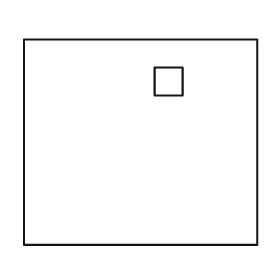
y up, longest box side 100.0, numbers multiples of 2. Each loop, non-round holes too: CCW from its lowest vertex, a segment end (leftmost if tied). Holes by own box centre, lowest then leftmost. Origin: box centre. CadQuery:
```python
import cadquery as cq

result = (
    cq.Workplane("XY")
    .moveTo(-50.0, -44.0)
    .lineTo(50.0, -44.0)
    .lineTo(50.0, 44.0)
    .lineTo(-50.0, 44.0)
    .close()
    .moveTo(6.0, 20.0)
    .lineTo(18.0, 20.0)
    .lineTo(18.0, 32.0)
    .lineTo(6.0, 32.0)
    .close()
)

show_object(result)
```